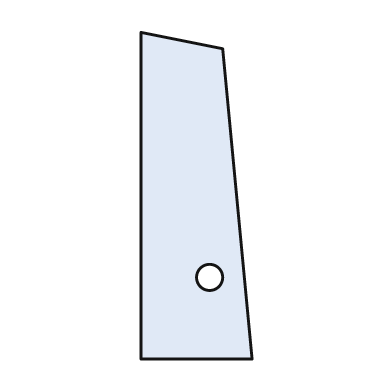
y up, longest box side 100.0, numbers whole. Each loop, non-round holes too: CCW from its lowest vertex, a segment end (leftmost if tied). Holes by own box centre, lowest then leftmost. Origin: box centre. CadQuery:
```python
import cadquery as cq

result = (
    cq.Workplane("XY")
    .moveTo(-17.0, -50.0)
    .lineTo(17.0, -50.0)
    .lineTo(8.0, 45.0)
    .lineTo(-17.0, 50.0)
    .close()
    .moveTo(4.0, -25.0)
    .circle(4.0)
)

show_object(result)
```